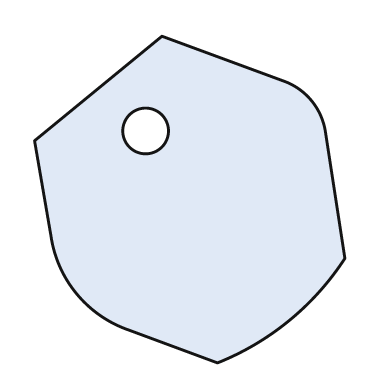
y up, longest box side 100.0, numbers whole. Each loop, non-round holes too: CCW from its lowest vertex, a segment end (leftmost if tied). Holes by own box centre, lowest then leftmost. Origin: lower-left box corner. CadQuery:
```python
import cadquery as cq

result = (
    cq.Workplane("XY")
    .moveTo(56.0, 0.0)
    .threePointArc((78.0, 13.0), (95.0, 32.0))
    .lineTo(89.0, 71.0)
    .threePointArc((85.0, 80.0), (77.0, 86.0))
    .lineTo(39.0, 100.0)
    .lineTo(0.0, 68.0)
    .lineTo(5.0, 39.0)
    .threePointArc((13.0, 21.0), (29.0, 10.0))
    .close()
    .moveTo(34.0, 71.0)
    .circle(7.0)
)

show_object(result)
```